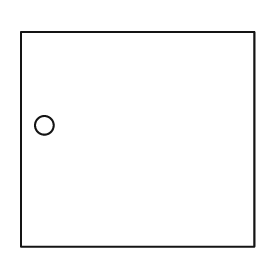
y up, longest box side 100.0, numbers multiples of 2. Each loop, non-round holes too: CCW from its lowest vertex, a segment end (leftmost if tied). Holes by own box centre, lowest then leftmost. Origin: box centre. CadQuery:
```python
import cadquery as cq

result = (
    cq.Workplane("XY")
    .moveTo(-50.0, -46.0)
    .lineTo(50.0, -46.0)
    .lineTo(50.0, 46.0)
    .lineTo(-50.0, 46.0)
    .close()
    .moveTo(-40.0, 6.0)
    .circle(4.0)
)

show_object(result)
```